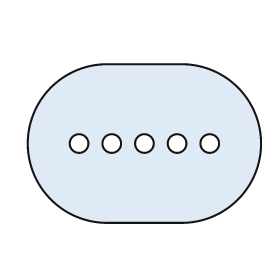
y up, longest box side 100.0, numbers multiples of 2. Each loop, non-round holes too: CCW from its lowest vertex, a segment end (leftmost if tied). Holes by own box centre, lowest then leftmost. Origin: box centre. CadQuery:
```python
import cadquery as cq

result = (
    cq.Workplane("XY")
    .moveTo(-16.0, -34.0)
    .lineTo(16.0, -34.0)
    .threePointArc((50.0, 0.0), (16.0, 34.0))
    .lineTo(-16.0, 34.0)
    .threePointArc((-50.0, 0.0), (-16.0, -34.0))
    .close()
    .moveTo(-28.0, 0.0)
    .circle(4.0)
    .moveTo(-14.0, 0.0)
    .circle(4.0)
    .moveTo(0.0, 0.0)
    .circle(4.0)
    .moveTo(14.0, 0.0)
    .circle(4.0)
    .moveTo(28.0, 0.0)
    .circle(4.0)
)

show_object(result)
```